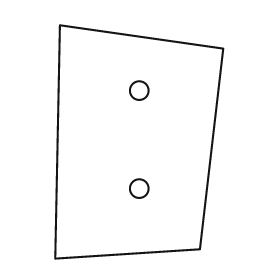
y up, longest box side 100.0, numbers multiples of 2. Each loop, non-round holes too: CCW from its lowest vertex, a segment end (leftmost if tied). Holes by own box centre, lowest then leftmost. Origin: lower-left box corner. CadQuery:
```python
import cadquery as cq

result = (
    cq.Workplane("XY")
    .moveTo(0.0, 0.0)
    .lineTo(62.0, 4.0)
    .lineTo(72.0, 90.0)
    .lineTo(2.0, 100.0)
    .close()
    .moveTo(36.0, 30.0)
    .circle(4.0)
    .moveTo(36.0, 72.0)
    .circle(4.0)
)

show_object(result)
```